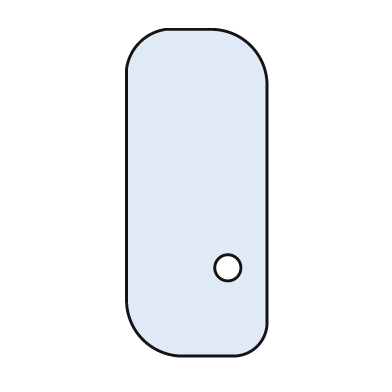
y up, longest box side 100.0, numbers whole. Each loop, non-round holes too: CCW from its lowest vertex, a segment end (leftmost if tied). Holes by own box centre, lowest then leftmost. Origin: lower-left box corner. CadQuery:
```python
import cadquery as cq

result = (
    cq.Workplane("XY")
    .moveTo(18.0, 0.0)
    .lineTo(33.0, 0.0)
    .threePointArc((40.0, 3.0), (43.0, 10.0))
    .lineTo(43.0, 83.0)
    .threePointArc((38.0, 95.0), (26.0, 100.0))
    .lineTo(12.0, 100.0)
    .threePointArc((4.0, 96.0), (0.0, 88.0))
    .lineTo(0.0, 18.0)
    .threePointArc((5.0, 5.0), (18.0, 0.0))
    .close()
    .moveTo(31.0, 27.0)
    .circle(4.0)
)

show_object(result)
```